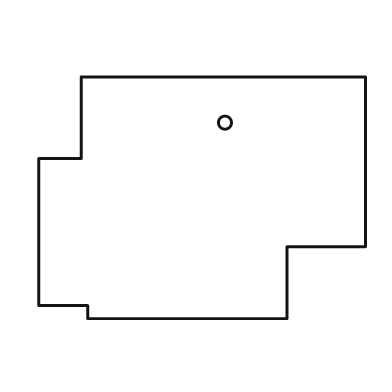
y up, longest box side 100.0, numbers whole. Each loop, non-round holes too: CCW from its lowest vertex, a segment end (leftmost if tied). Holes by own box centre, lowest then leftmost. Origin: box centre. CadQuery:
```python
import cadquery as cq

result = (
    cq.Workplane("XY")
    .moveTo(-35.0, -37.0)
    .lineTo(26.0, -37.0)
    .lineTo(26.0, -15.0)
    .lineTo(50.0, -15.0)
    .lineTo(50.0, 37.0)
    .lineTo(-37.0, 37.0)
    .lineTo(-37.0, 12.0)
    .lineTo(-50.0, 12.0)
    .lineTo(-50.0, -33.0)
    .lineTo(-35.0, -33.0)
    .close()
    .moveTo(7.0, 23.0)
    .circle(2.0)
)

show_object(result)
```